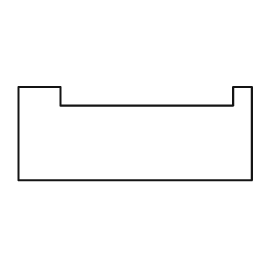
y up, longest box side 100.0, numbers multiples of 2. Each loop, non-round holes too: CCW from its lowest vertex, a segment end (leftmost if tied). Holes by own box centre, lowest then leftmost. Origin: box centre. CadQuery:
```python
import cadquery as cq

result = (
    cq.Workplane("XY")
    .moveTo(-50.0, -20.0)
    .lineTo(50.0, -20.0)
    .lineTo(50.0, 20.0)
    .lineTo(42.0, 20.0)
    .lineTo(42.0, 12.0)
    .lineTo(-32.0, 12.0)
    .lineTo(-32.0, 20.0)
    .lineTo(-50.0, 20.0)
    .close()
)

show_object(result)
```